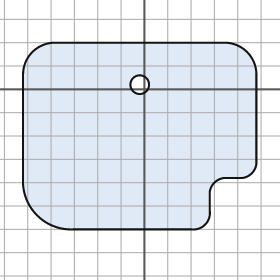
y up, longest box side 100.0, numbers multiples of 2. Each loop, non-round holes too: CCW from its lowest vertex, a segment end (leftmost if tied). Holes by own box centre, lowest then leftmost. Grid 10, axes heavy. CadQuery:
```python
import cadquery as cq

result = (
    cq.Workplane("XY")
    .moveTo(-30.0, -60.0)
    .lineTo(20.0, -60.0)
    .threePointArc((26.0, -58.0), (28.0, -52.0))
    .lineTo(28.0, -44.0)
    .threePointArc((30.0, -40.0), (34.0, -38.0))
    .lineTo(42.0, -38.0)
    .threePointArc((46.0, -36.0), (48.0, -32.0))
    .lineTo(48.0, 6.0)
    .threePointArc((44.0, 16.0), (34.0, 20.0))
    .lineTo(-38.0, 20.0)
    .threePointArc((-48.0, 16.0), (-52.0, 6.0))
    .lineTo(-52.0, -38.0)
    .threePointArc((-46.0, -54.0), (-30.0, -60.0))
    .close()
    .moveTo(-2.0, 2.0)
    .circle(4.0)
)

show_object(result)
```